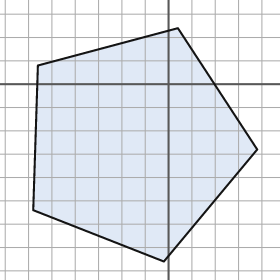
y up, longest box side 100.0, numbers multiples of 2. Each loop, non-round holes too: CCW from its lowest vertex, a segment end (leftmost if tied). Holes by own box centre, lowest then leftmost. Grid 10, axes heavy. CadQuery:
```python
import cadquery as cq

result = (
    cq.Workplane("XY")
    .moveTo(-2.0, -76.0)
    .lineTo(38.0, -28.0)
    .lineTo(4.0, 24.0)
    .lineTo(-56.0, 8.0)
    .lineTo(-58.0, -54.0)
    .close()
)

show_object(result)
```